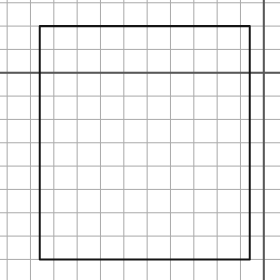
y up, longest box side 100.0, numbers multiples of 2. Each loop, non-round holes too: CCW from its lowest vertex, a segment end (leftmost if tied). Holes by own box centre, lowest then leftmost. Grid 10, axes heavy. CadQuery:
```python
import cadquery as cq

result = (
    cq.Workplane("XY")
    .moveTo(-96.0, -80.0)
    .lineTo(-6.0, -80.0)
    .lineTo(-6.0, 20.0)
    .lineTo(-96.0, 20.0)
    .close()
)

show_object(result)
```